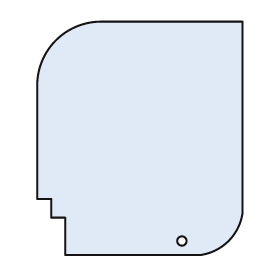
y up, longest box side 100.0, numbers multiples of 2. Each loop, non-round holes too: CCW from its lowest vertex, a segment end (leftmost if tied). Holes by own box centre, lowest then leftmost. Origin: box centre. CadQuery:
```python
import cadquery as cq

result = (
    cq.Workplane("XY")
    .moveTo(-32.0, -50.0)
    .lineTo(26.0, -50.0)
    .threePointArc((38.0, -44.0), (44.0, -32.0))
    .lineTo(44.0, 50.0)
    .lineTo(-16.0, 50.0)
    .threePointArc((-36.0, 42.0), (-44.0, 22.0))
    .lineTo(-44.0, -26.0)
    .lineTo(-38.0, -26.0)
    .lineTo(-38.0, -34.0)
    .lineTo(-32.0, -34.0)
    .close()
    .moveTo(18.0, -44.0)
    .circle(2.0)
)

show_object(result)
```